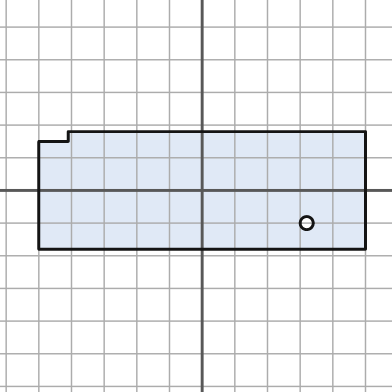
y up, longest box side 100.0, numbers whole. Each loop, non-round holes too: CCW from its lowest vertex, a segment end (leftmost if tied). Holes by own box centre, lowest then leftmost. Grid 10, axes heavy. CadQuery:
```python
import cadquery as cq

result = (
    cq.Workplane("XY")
    .moveTo(-50.0, -18.0)
    .lineTo(50.0, -18.0)
    .lineTo(50.0, 18.0)
    .lineTo(-41.0, 18.0)
    .lineTo(-41.0, 15.0)
    .lineTo(-50.0, 15.0)
    .close()
    .moveTo(32.0, -10.0)
    .circle(2.0)
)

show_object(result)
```